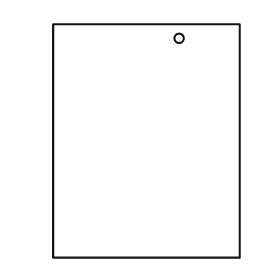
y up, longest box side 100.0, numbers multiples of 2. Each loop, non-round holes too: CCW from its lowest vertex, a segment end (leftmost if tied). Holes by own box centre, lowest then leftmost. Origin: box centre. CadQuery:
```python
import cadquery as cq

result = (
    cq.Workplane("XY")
    .moveTo(-40.0, -50.0)
    .lineTo(40.0, -50.0)
    .lineTo(40.0, 50.0)
    .lineTo(-40.0, 50.0)
    .close()
    .moveTo(14.0, 44.0)
    .circle(2.0)
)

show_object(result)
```